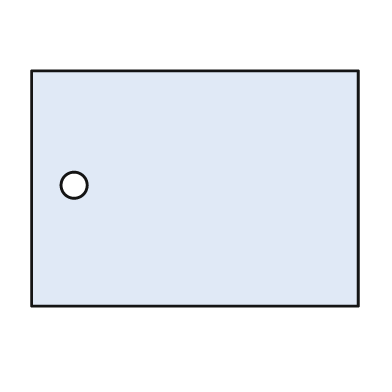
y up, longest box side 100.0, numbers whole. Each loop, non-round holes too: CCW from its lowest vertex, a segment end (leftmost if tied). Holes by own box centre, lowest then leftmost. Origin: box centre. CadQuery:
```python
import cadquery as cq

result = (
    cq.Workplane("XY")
    .moveTo(-50.0, -36.0)
    .lineTo(50.0, -36.0)
    .lineTo(50.0, 36.0)
    .lineTo(-50.0, 36.0)
    .close()
    .moveTo(-37.0, 1.0)
    .circle(4.0)
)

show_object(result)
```